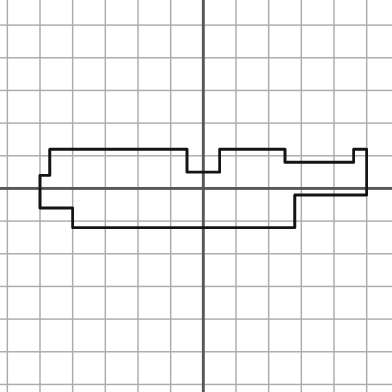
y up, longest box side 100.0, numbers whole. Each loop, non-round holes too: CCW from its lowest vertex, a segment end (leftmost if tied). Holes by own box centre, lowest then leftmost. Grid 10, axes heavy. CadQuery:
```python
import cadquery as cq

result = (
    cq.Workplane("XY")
    .moveTo(-40.0, -12.0)
    .lineTo(28.0, -12.0)
    .lineTo(28.0, -2.0)
    .lineTo(50.0, -2.0)
    .lineTo(50.0, 12.0)
    .lineTo(46.0, 12.0)
    .lineTo(46.0, 8.0)
    .lineTo(25.0, 8.0)
    .lineTo(25.0, 12.0)
    .lineTo(5.0, 12.0)
    .lineTo(5.0, 5.0)
    .lineTo(-5.0, 5.0)
    .lineTo(-5.0, 12.0)
    .lineTo(-47.0, 12.0)
    .lineTo(-47.0, 4.0)
    .lineTo(-50.0, 4.0)
    .lineTo(-50.0, -6.0)
    .lineTo(-40.0, -6.0)
    .close()
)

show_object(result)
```